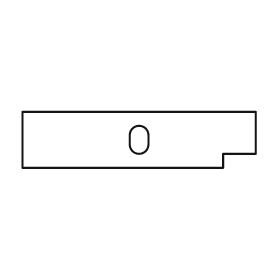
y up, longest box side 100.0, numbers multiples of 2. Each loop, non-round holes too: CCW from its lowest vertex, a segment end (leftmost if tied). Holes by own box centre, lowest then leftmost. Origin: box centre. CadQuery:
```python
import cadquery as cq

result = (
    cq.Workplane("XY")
    .moveTo(-50.0, -12.0)
    .lineTo(36.0, -12.0)
    .lineTo(36.0, -6.0)
    .lineTo(50.0, -6.0)
    .lineTo(50.0, 12.0)
    .lineTo(-50.0, 12.0)
    .close()
    .moveTo(-4.0, -2.0)
    .threePointArc((0.0, -6.0), (4.0, -2.0))
    .lineTo(4.0, 2.0)
    .threePointArc((0.0, 6.0), (-4.0, 2.0))
    .close()
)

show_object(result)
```